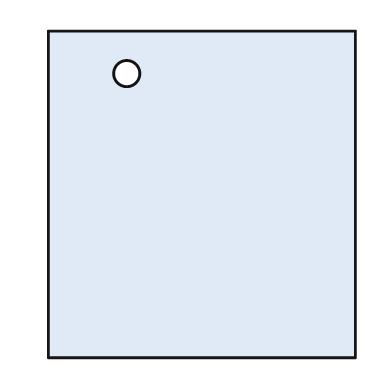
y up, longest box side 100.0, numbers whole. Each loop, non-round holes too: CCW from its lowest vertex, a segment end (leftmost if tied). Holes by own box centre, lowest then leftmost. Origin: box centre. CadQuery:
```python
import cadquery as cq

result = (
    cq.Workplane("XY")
    .moveTo(-47.0, -50.0)
    .lineTo(47.0, -50.0)
    .lineTo(47.0, 50.0)
    .lineTo(-47.0, 50.0)
    .close()
    .moveTo(-23.0, 37.0)
    .circle(4.0)
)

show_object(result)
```